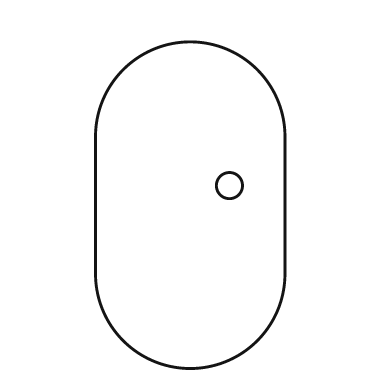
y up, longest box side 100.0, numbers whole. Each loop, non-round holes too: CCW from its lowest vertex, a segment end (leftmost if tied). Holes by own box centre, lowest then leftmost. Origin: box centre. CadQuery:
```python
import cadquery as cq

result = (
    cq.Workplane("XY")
    .moveTo(-29.0, -21.0)
    .threePointArc((0.0, -50.0), (29.0, -21.0))
    .lineTo(29.0, 21.0)
    .threePointArc((0.0, 50.0), (-29.0, 21.0))
    .close()
    .moveTo(12.0, 6.0)
    .circle(4.0)
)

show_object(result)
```